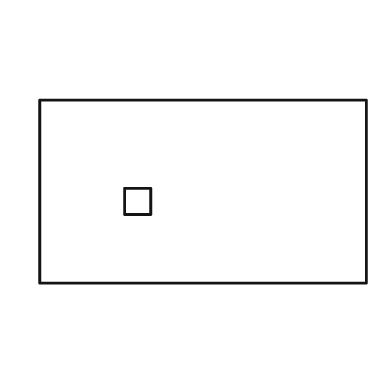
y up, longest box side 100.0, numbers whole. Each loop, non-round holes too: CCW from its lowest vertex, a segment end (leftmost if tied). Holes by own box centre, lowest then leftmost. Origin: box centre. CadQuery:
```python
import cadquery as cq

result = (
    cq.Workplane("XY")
    .moveTo(-50.0, -28.0)
    .lineTo(50.0, -28.0)
    .lineTo(50.0, 28.0)
    .lineTo(-50.0, 28.0)
    .close()
    .moveTo(-24.0, -7.0)
    .lineTo(-16.0, -7.0)
    .lineTo(-16.0, 1.0)
    .lineTo(-24.0, 1.0)
    .close()
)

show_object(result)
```